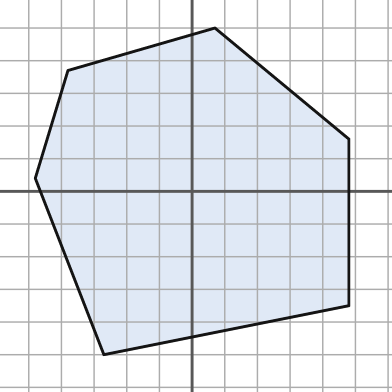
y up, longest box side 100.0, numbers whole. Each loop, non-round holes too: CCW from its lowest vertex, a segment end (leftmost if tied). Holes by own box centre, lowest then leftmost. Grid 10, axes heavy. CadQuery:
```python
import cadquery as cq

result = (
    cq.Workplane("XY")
    .moveTo(-27.0, -50.0)
    .lineTo(48.0, -35.0)
    .lineTo(48.0, 16.0)
    .lineTo(7.0, 50.0)
    .lineTo(-38.0, 37.0)
    .lineTo(-48.0, 4.0)
    .close()
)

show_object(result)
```